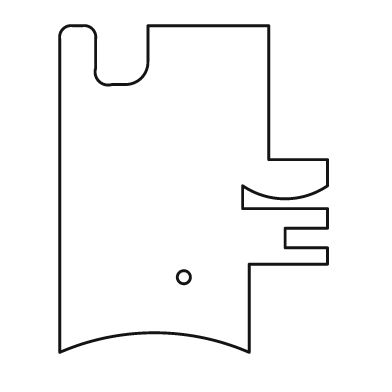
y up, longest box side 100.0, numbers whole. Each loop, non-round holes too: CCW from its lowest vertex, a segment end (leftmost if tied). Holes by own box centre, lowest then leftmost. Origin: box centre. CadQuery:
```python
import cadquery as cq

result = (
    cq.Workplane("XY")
    .moveTo(-41.0, -50.0)
    .threePointArc((-12.0, -44.0), (17.0, -50.0))
    .lineTo(17.0, -23.0)
    .lineTo(41.0, -23.0)
    .lineTo(41.0, -18.0)
    .lineTo(28.0, -18.0)
    .lineTo(28.0, -12.0)
    .lineTo(41.0, -12.0)
    .lineTo(41.0, -6.0)
    .lineTo(15.0, -6.0)
    .lineTo(15.0, 1.0)
    .threePointArc((28.0, -3.0), (41.0, 1.0))
    .lineTo(41.0, 9.0)
    .lineTo(23.0, 9.0)
    .lineTo(23.0, 50.0)
    .lineTo(-14.0, 50.0)
    .lineTo(-14.0, 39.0)
    .threePointArc((-16.0, 34.0), (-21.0, 32.0))
    .lineTo(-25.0, 32.0)
    .threePointArc((-29.0, 33.0), (-30.0, 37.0))
    .lineTo(-30.0, 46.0)
    .threePointArc((-31.0, 49.0), (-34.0, 50.0))
    .lineTo(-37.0, 50.0)
    .threePointArc((-40.0, 49.0), (-41.0, 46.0))
    .close()
    .moveTo(-3.0, -27.0)
    .circle(2.0)
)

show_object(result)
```